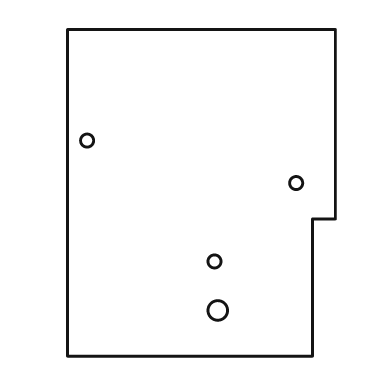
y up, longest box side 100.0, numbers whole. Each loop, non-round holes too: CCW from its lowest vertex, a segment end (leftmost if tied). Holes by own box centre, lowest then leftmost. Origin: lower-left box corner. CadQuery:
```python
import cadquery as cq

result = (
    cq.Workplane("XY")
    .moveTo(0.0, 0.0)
    .lineTo(75.0, 0.0)
    .lineTo(75.0, 42.0)
    .lineTo(82.0, 42.0)
    .lineTo(82.0, 100.0)
    .lineTo(0.0, 100.0)
    .close()
    .moveTo(46.0, 14.0)
    .circle(3.0)
    .moveTo(45.0, 29.0)
    .circle(2.0)
    .moveTo(70.0, 53.0)
    .circle(2.0)
    .moveTo(6.0, 66.0)
    .circle(2.0)
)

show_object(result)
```